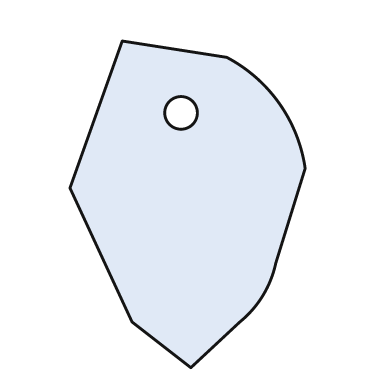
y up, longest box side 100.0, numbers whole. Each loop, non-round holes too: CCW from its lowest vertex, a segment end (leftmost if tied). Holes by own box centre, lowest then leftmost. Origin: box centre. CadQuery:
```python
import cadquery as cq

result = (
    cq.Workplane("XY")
    .moveTo(1.0, -50.0)
    .lineTo(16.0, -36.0)
    .threePointArc((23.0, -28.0), (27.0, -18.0))
    .lineTo(36.0, 11.0)
    .threePointArc((28.0, 31.0), (12.0, 45.0))
    .lineTo(-20.0, 50.0)
    .lineTo(-36.0, 5.0)
    .lineTo(-17.0, -36.0)
    .close()
    .moveTo(-2.0, 28.0)
    .circle(5.0)
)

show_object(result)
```